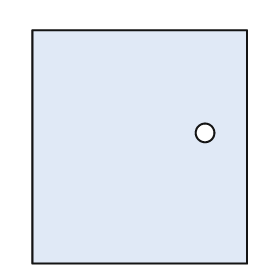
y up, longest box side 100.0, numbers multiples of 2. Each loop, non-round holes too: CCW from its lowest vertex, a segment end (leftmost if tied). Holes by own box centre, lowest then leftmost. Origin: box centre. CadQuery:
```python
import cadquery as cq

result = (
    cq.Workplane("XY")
    .moveTo(-46.0, -50.0)
    .lineTo(46.0, -50.0)
    .lineTo(46.0, 50.0)
    .lineTo(-46.0, 50.0)
    .close()
    .moveTo(28.0, 6.0)
    .circle(4.0)
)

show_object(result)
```